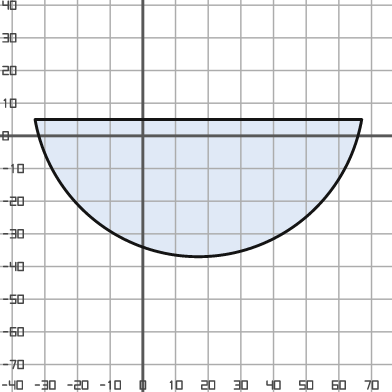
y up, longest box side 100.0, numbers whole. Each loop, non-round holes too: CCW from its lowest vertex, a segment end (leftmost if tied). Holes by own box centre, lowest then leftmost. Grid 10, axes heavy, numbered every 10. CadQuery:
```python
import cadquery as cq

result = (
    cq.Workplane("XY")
    .moveTo(-33.0, 5.0)
    .threePointArc((17.0, -37.0), (67.0, 5.0))
    .close()
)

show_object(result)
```